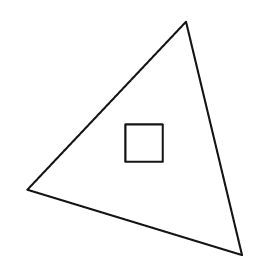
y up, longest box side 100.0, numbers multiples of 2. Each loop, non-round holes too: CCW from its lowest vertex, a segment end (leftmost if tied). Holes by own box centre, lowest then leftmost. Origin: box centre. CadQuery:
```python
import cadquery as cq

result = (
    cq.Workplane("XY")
    .moveTo(46.0, -50.0)
    .lineTo(22.0, 50.0)
    .lineTo(-46.0, -22.0)
    .close()
    .moveTo(-4.0, -10.0)
    .lineTo(12.0, -10.0)
    .lineTo(12.0, 6.0)
    .lineTo(-4.0, 6.0)
    .close()
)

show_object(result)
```